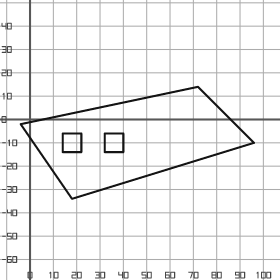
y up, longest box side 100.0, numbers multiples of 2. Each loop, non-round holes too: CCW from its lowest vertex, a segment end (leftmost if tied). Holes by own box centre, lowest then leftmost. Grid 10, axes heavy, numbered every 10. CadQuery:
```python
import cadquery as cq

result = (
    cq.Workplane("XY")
    .moveTo(18.0, -34.0)
    .lineTo(96.0, -10.0)
    .lineTo(72.0, 14.0)
    .lineTo(-4.0, -2.0)
    .close()
    .moveTo(14.0, -14.0)
    .lineTo(22.0, -14.0)
    .lineTo(22.0, -6.0)
    .lineTo(14.0, -6.0)
    .close()
    .moveTo(32.0, -14.0)
    .lineTo(40.0, -14.0)
    .lineTo(40.0, -6.0)
    .lineTo(32.0, -6.0)
    .close()
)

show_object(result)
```